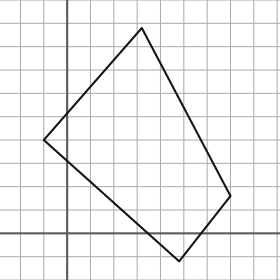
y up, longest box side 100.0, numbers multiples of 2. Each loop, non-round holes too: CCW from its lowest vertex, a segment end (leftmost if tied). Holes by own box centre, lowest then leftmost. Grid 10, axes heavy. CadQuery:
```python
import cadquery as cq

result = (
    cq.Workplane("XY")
    .moveTo(48.0, -12.0)
    .lineTo(70.0, 16.0)
    .lineTo(32.0, 88.0)
    .lineTo(-10.0, 40.0)
    .close()
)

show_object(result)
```